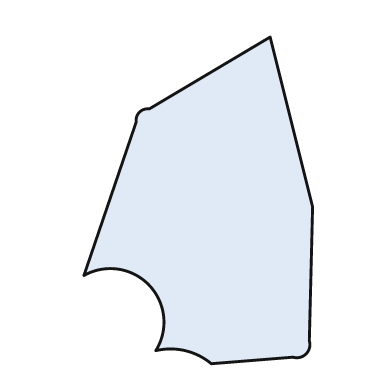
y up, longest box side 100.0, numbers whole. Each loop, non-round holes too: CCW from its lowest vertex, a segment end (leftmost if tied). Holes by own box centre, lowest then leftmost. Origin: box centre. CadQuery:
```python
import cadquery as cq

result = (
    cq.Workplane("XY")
    .moveTo(4.0, -50.0)
    .lineTo(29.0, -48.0)
    .threePointArc((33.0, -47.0), (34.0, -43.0))
    .lineTo(35.0, -2.0)
    .lineTo(22.0, 50.0)
    .lineTo(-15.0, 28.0)
    .threePointArc((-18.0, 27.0), (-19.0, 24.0))
    .lineTo(-35.0, -23.0)
    .threePointArc((-15.0, -26.0), (-13.0, -46.0))
    .threePointArc((-4.0, -46.0), (4.0, -50.0))
    .close()
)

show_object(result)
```